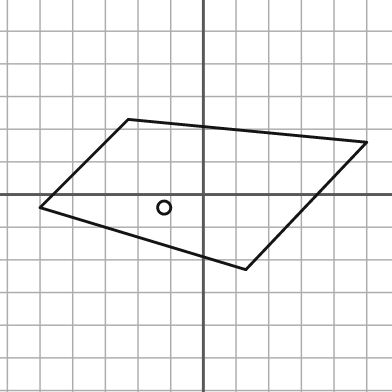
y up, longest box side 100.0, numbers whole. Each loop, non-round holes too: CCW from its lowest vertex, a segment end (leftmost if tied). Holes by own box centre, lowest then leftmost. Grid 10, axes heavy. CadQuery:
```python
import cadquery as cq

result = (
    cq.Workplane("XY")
    .moveTo(13.0, -23.0)
    .lineTo(50.0, 16.0)
    .lineTo(-23.0, 23.0)
    .lineTo(-50.0, -4.0)
    .close()
    .moveTo(-12.0, -4.0)
    .circle(2.0)
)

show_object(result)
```